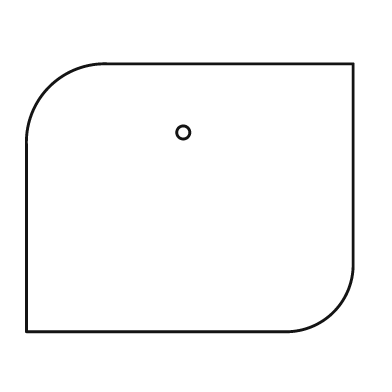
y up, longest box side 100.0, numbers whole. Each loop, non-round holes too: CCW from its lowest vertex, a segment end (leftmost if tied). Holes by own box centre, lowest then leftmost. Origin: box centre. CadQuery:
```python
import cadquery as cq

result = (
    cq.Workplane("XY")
    .moveTo(-50.0, -41.0)
    .lineTo(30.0, -41.0)
    .threePointArc((44.0, -35.0), (50.0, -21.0))
    .lineTo(50.0, 41.0)
    .lineTo(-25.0, 41.0)
    .threePointArc((-43.0, 34.0), (-50.0, 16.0))
    .close()
    .moveTo(-2.0, 20.0)
    .circle(2.0)
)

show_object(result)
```